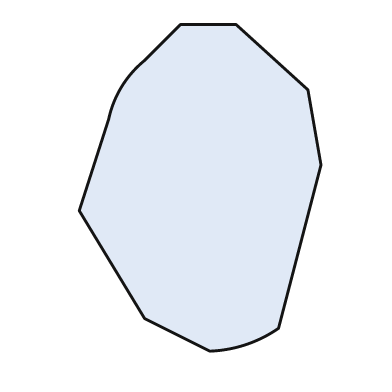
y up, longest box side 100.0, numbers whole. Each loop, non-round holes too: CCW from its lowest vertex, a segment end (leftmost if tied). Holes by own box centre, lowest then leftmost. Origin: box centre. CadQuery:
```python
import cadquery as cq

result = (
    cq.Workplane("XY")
    .moveTo(3.0, -50.0)
    .threePointArc((14.0, -48.0), (24.0, -43.0))
    .lineTo(37.0, 7.0)
    .lineTo(33.0, 30.0)
    .lineTo(11.0, 50.0)
    .lineTo(-6.0, 50.0)
    .lineTo(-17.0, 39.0)
    .threePointArc((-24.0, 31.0), (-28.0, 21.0))
    .lineTo(-37.0, -7.0)
    .lineTo(-17.0, -40.0)
    .close()
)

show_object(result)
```